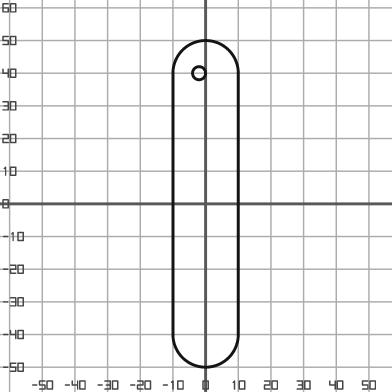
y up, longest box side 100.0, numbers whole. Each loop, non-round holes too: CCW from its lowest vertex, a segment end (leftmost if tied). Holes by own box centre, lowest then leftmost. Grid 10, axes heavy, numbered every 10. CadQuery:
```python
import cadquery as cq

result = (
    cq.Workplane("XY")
    .moveTo(-10.0, -40.0)
    .threePointArc((0.0, -50.0), (10.0, -40.0))
    .lineTo(10.0, 40.0)
    .threePointArc((0.0, 50.0), (-10.0, 40.0))
    .close()
    .moveTo(-2.0, 40.0)
    .circle(2.0)
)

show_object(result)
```